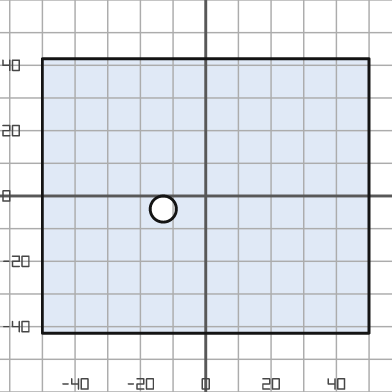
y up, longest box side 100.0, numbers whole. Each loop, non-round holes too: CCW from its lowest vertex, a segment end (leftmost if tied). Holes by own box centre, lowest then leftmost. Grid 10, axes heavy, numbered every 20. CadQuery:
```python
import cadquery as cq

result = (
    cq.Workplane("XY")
    .moveTo(-50.0, -42.0)
    .lineTo(50.0, -42.0)
    .lineTo(50.0, 42.0)
    .lineTo(-50.0, 42.0)
    .close()
    .moveTo(-13.0, -4.0)
    .circle(4.0)
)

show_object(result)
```